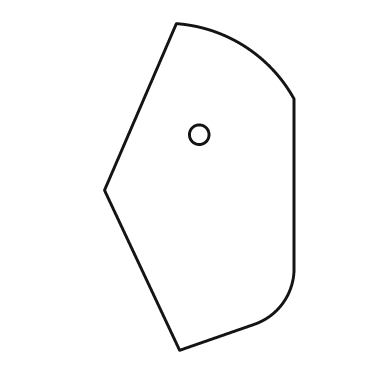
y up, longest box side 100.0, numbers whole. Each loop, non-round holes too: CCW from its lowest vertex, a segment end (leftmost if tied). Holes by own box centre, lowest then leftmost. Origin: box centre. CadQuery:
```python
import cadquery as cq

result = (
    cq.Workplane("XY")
    .moveTo(-6.0, -50.0)
    .lineTo(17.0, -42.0)
    .threePointArc((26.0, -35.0), (29.0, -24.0))
    .lineTo(29.0, 27.0)
    .threePointArc((14.0, 43.0), (-7.0, 50.0))
    .lineTo(-29.0, -1.0)
    .close()
    .moveTo(0.0, 16.0)
    .circle(3.0)
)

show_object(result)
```